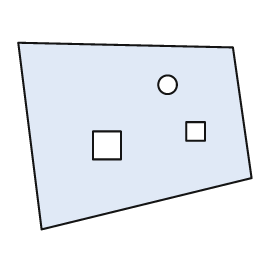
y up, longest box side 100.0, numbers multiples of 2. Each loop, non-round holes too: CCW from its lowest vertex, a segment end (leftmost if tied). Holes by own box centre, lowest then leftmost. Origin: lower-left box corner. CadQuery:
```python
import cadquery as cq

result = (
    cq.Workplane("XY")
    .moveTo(10.0, 0.0)
    .lineTo(100.0, 22.0)
    .lineTo(92.0, 78.0)
    .lineTo(0.0, 80.0)
    .close()
    .moveTo(32.0, 30.0)
    .lineTo(44.0, 30.0)
    .lineTo(44.0, 42.0)
    .lineTo(32.0, 42.0)
    .close()
    .moveTo(72.0, 38.0)
    .lineTo(80.0, 38.0)
    .lineTo(80.0, 46.0)
    .lineTo(72.0, 46.0)
    .close()
    .moveTo(64.0, 62.0)
    .circle(4.0)
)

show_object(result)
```